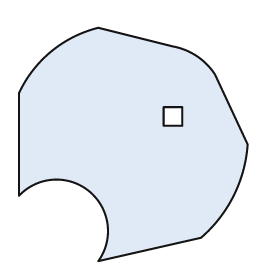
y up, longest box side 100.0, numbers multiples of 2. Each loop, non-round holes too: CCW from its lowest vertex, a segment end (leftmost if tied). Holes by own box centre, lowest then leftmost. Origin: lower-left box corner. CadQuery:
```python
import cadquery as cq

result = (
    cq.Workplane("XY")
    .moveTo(34.0, 0.0)
    .lineTo(78.0, 10.0)
    .threePointArc((92.0, 28.0), (98.0, 50.0))
    .lineTo(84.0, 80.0)
    .threePointArc((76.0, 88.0), (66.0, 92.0))
    .lineTo(34.0, 100.0)
    .threePointArc((14.0, 90.0), (0.0, 72.0))
    .lineTo(0.0, 28.0)
    .threePointArc((30.0, 30.0), (34.0, 0.0))
    .close()
    .moveTo(62.0, 58.0)
    .lineTo(70.0, 58.0)
    .lineTo(70.0, 66.0)
    .lineTo(62.0, 66.0)
    .close()
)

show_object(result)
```